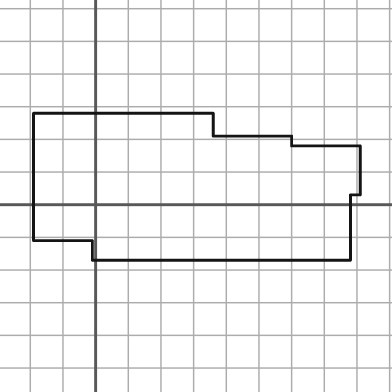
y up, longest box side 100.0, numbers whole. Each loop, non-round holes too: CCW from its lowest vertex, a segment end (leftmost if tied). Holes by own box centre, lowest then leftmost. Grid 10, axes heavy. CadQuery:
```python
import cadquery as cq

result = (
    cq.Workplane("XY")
    .moveTo(-1.0, -17.0)
    .lineTo(78.0, -17.0)
    .lineTo(78.0, 3.0)
    .lineTo(81.0, 3.0)
    .lineTo(81.0, 18.0)
    .lineTo(60.0, 18.0)
    .lineTo(60.0, 21.0)
    .lineTo(36.0, 21.0)
    .lineTo(36.0, 28.0)
    .lineTo(-19.0, 28.0)
    .lineTo(-19.0, -11.0)
    .lineTo(-1.0, -11.0)
    .close()
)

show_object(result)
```